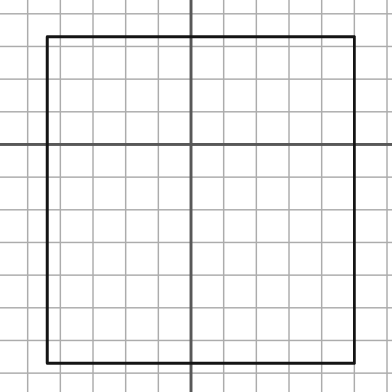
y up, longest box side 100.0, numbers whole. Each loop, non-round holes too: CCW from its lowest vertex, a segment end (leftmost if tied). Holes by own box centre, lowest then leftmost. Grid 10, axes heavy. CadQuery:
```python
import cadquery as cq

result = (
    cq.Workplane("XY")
    .moveTo(-44.0, -67.0)
    .lineTo(50.0, -67.0)
    .lineTo(50.0, 33.0)
    .lineTo(-44.0, 33.0)
    .close()
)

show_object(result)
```